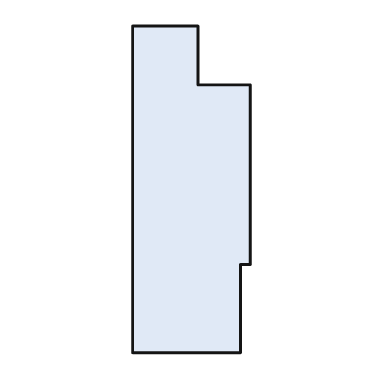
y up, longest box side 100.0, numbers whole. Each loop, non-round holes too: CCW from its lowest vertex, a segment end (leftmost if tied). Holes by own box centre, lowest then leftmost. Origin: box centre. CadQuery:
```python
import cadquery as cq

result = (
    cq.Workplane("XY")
    .moveTo(-18.0, -50.0)
    .lineTo(15.0, -50.0)
    .lineTo(15.0, -23.0)
    .lineTo(18.0, -23.0)
    .lineTo(18.0, 32.0)
    .lineTo(2.0, 32.0)
    .lineTo(2.0, 50.0)
    .lineTo(-18.0, 50.0)
    .close()
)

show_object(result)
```